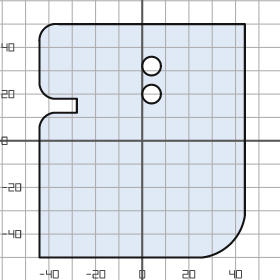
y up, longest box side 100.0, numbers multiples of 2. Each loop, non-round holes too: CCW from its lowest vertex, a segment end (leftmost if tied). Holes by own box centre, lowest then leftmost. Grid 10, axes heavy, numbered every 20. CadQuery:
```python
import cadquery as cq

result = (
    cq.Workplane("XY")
    .moveTo(-44.0, -50.0)
    .lineTo(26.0, -50.0)
    .threePointArc((38.0, -44.0), (44.0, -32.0))
    .lineTo(44.0, 50.0)
    .lineTo(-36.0, 50.0)
    .threePointArc((-42.0, 48.0), (-44.0, 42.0))
    .lineTo(-44.0, 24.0)
    .threePointArc((-42.0, 20.0), (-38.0, 18.0))
    .lineTo(-28.0, 18.0)
    .lineTo(-28.0, 12.0)
    .lineTo(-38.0, 12.0)
    .threePointArc((-42.0, 10.0), (-44.0, 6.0))
    .close()
    .moveTo(4.0, 20.0)
    .circle(4.0)
    .moveTo(4.0, 32.0)
    .circle(4.0)
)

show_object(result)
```